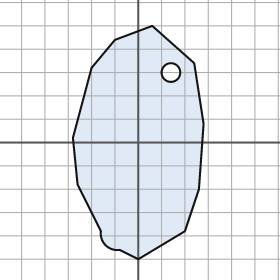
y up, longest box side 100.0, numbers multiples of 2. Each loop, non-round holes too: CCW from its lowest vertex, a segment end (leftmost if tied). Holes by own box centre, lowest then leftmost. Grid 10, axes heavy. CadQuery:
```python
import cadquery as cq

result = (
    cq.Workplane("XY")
    .moveTo(0.0, -50.0)
    .lineTo(20.0, -38.0)
    .lineTo(26.0, -20.0)
    .lineTo(28.0, 8.0)
    .lineTo(24.0, 34.0)
    .lineTo(6.0, 50.0)
    .lineTo(-10.0, 44.0)
    .lineTo(-20.0, 32.0)
    .lineTo(-28.0, 2.0)
    .lineTo(-26.0, -18.0)
    .lineTo(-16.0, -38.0)
    .threePointArc((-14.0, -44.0), (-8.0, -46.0))
    .close()
    .moveTo(14.0, 30.0)
    .circle(4.0)
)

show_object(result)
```